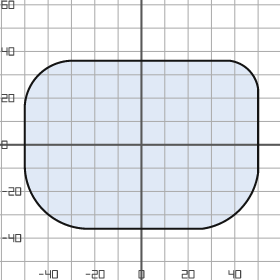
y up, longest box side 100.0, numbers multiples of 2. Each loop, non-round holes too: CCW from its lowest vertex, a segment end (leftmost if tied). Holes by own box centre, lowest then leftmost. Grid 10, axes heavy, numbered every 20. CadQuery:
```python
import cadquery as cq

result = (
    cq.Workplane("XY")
    .moveTo(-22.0, -36.0)
    .lineTo(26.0, -36.0)
    .threePointArc((42.0, -28.0), (50.0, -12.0))
    .lineTo(50.0, 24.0)
    .threePointArc((46.0, 32.0), (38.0, 36.0))
    .lineTo(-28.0, 36.0)
    .threePointArc((-44.0, 30.0), (-50.0, 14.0))
    .lineTo(-50.0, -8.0)
    .threePointArc((-42.0, -28.0), (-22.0, -36.0))
    .close()
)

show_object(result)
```